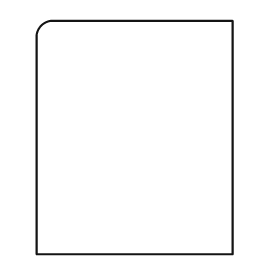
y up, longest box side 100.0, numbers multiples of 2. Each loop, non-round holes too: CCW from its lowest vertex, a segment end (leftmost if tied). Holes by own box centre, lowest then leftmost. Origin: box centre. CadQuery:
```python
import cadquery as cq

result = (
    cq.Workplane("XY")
    .moveTo(-42.0, -50.0)
    .lineTo(42.0, -50.0)
    .lineTo(42.0, 50.0)
    .lineTo(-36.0, 50.0)
    .threePointArc((-40.0, 48.0), (-42.0, 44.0))
    .close()
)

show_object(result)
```